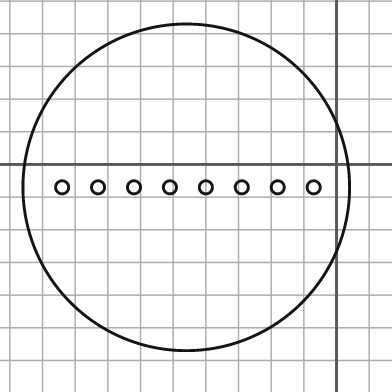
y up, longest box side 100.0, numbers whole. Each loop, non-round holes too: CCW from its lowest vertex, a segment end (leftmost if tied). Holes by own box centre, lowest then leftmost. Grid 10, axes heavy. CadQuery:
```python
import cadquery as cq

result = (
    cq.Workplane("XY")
    .moveTo(-46.0, -7.0)
    .circle(50.0)
    .moveTo(-84.0, -7.0)
    .circle(2.0)
    .moveTo(-73.0, -7.0)
    .circle(2.0)
    .moveTo(-62.0, -7.0)
    .circle(2.0)
    .moveTo(-51.0, -7.0)
    .circle(2.0)
    .moveTo(-40.0, -7.0)
    .circle(2.0)
    .moveTo(-29.0, -7.0)
    .circle(2.0)
    .moveTo(-18.0, -7.0)
    .circle(2.0)
    .moveTo(-7.0, -7.0)
    .circle(2.0)
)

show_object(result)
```